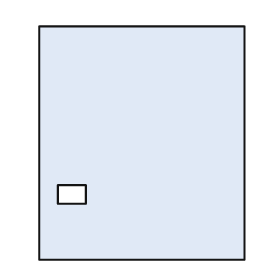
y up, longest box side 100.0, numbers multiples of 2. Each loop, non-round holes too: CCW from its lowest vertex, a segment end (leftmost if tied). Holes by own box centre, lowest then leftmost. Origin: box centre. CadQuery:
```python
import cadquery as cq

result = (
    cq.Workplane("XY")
    .moveTo(-44.0, -50.0)
    .lineTo(44.0, -50.0)
    .lineTo(44.0, 50.0)
    .lineTo(-44.0, 50.0)
    .close()
    .moveTo(-36.0, -26.0)
    .lineTo(-24.0, -26.0)
    .lineTo(-24.0, -18.0)
    .lineTo(-36.0, -18.0)
    .close()
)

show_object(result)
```